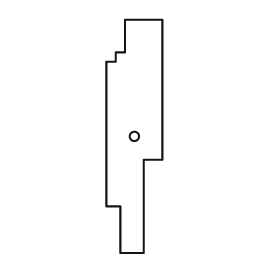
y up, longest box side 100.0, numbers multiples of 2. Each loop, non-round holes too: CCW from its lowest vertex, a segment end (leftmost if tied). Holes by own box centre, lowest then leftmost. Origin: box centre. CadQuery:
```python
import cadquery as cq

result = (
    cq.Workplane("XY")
    .moveTo(-6.0, -50.0)
    .lineTo(4.0, -50.0)
    .lineTo(4.0, -10.0)
    .lineTo(12.0, -10.0)
    .lineTo(12.0, 50.0)
    .lineTo(-4.0, 50.0)
    .lineTo(-4.0, 36.0)
    .lineTo(-8.0, 36.0)
    .lineTo(-8.0, 32.0)
    .lineTo(-12.0, 32.0)
    .lineTo(-12.0, -30.0)
    .lineTo(-6.0, -30.0)
    .close()
    .moveTo(0.0, 0.0)
    .circle(2.0)
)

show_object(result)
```